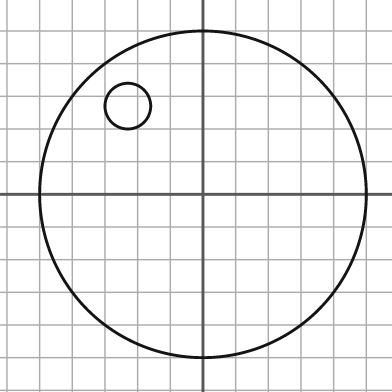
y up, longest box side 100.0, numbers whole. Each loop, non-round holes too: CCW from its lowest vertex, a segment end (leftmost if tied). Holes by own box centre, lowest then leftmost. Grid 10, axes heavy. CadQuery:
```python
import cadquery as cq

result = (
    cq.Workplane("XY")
    .moveTo(0.0, 0.0)
    .circle(50.0)
    .moveTo(-23.0, 27.0)
    .circle(7.0)
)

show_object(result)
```